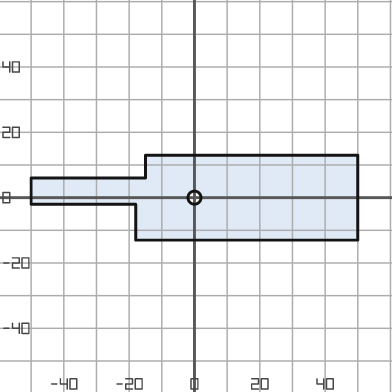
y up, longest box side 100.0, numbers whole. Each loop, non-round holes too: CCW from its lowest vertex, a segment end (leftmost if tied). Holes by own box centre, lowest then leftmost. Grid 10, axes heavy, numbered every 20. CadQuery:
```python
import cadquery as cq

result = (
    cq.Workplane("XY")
    .moveTo(-18.0, -13.0)
    .lineTo(50.0, -13.0)
    .lineTo(50.0, 13.0)
    .lineTo(-15.0, 13.0)
    .lineTo(-15.0, 6.0)
    .lineTo(-50.0, 6.0)
    .lineTo(-50.0, -2.0)
    .lineTo(-18.0, -2.0)
    .close()
    .moveTo(0.0, 0.0)
    .circle(2.0)
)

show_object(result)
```